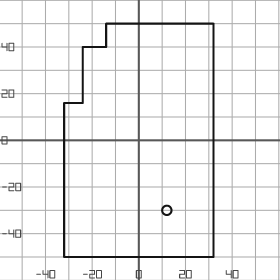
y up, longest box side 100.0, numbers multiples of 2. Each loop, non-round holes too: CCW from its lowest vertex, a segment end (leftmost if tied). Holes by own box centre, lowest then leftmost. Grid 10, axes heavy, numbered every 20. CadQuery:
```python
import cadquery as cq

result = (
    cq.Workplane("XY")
    .moveTo(-32.0, -50.0)
    .lineTo(32.0, -50.0)
    .lineTo(32.0, 50.0)
    .lineTo(-14.0, 50.0)
    .lineTo(-14.0, 40.0)
    .lineTo(-24.0, 40.0)
    .lineTo(-24.0, 16.0)
    .lineTo(-32.0, 16.0)
    .close()
    .moveTo(12.0, -30.0)
    .circle(2.0)
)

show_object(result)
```